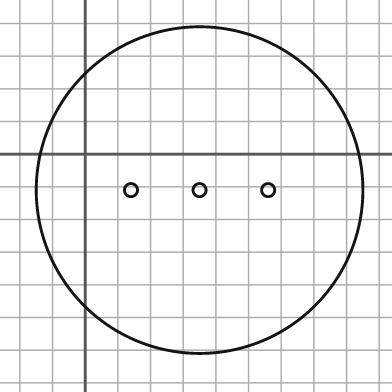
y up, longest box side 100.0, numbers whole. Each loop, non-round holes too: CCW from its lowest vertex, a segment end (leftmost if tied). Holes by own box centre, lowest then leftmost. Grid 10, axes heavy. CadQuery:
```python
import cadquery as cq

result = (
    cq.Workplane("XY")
    .moveTo(35.0, -11.0)
    .circle(50.0)
    .moveTo(14.0, -11.0)
    .circle(2.0)
    .moveTo(35.0, -11.0)
    .circle(2.0)
    .moveTo(56.0, -11.0)
    .circle(2.0)
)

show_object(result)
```